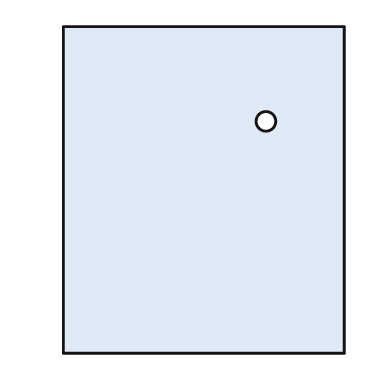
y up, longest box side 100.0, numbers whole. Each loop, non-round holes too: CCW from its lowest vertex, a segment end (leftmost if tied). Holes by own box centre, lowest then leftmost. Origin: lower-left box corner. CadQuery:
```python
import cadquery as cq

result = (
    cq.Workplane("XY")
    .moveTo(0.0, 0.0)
    .lineTo(86.0, 0.0)
    .lineTo(86.0, 100.0)
    .lineTo(0.0, 100.0)
    .close()
    .moveTo(62.0, 71.0)
    .circle(3.0)
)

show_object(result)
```